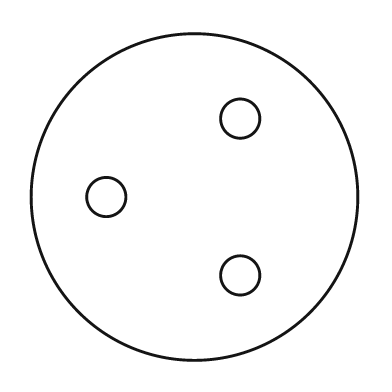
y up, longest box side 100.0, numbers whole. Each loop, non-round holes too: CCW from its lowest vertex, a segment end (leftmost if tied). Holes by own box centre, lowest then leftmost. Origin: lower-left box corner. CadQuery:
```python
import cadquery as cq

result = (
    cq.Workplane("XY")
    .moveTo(50.0, 50.0)
    .circle(50.0)
    .moveTo(64.0, 26.0)
    .circle(6.0)
    .moveTo(23.0, 50.0)
    .circle(6.0)
    .moveTo(64.0, 74.0)
    .circle(6.0)
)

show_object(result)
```